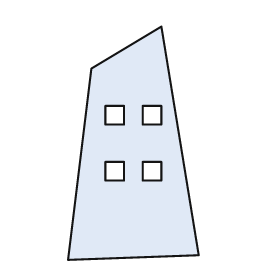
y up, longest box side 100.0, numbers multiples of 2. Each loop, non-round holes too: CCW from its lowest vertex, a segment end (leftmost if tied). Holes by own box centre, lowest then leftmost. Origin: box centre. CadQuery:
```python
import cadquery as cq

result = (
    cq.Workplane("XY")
    .moveTo(-28.0, -50.0)
    .lineTo(28.0, -48.0)
    .lineTo(12.0, 50.0)
    .lineTo(-18.0, 32.0)
    .close()
    .moveTo(-12.0, -16.0)
    .lineTo(-4.0, -16.0)
    .lineTo(-4.0, -8.0)
    .lineTo(-12.0, -8.0)
    .close()
    .moveTo(4.0, -16.0)
    .lineTo(12.0, -16.0)
    .lineTo(12.0, -8.0)
    .lineTo(4.0, -8.0)
    .close()
    .moveTo(-12.0, 8.0)
    .lineTo(-4.0, 8.0)
    .lineTo(-4.0, 16.0)
    .lineTo(-12.0, 16.0)
    .close()
    .moveTo(4.0, 8.0)
    .lineTo(12.0, 8.0)
    .lineTo(12.0, 16.0)
    .lineTo(4.0, 16.0)
    .close()
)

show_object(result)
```